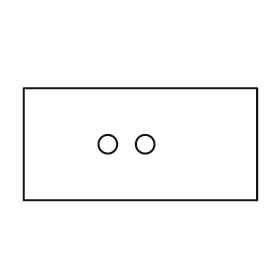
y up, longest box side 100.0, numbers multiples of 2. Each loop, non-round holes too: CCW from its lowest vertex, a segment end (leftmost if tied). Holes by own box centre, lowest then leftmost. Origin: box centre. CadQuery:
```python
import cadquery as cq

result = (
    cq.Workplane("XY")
    .moveTo(-50.0, -24.0)
    .lineTo(50.0, -24.0)
    .lineTo(50.0, 24.0)
    .lineTo(-50.0, 24.0)
    .close()
    .moveTo(-14.0, 0.0)
    .circle(4.0)
    .moveTo(2.0, 0.0)
    .circle(4.0)
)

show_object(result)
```